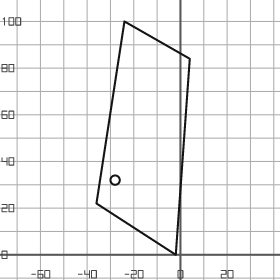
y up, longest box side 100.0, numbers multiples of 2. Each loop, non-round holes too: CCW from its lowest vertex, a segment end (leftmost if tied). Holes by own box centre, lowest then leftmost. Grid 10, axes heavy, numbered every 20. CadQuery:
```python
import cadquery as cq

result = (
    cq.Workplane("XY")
    .moveTo(-2.0, 0.0)
    .lineTo(4.0, 84.0)
    .lineTo(-24.0, 100.0)
    .lineTo(-36.0, 22.0)
    .close()
    .moveTo(-28.0, 32.0)
    .circle(2.0)
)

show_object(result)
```